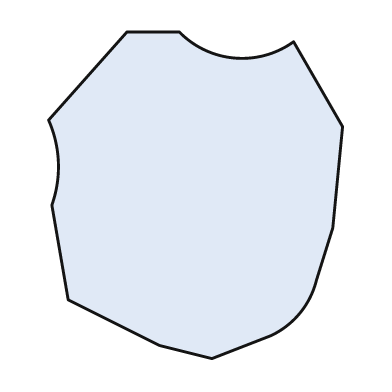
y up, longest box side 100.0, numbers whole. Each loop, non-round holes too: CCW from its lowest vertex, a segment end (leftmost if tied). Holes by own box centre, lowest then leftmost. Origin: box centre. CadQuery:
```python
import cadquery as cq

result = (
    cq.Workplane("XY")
    .moveTo(5.0, -50.0)
    .lineTo(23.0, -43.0)
    .threePointArc((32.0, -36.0), (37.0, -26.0))
    .lineTo(42.0, -10.0)
    .lineTo(45.0, 21.0)
    .lineTo(30.0, 47.0)
    .threePointArc((12.0, 42.0), (-5.0, 50.0))
    .lineTo(-21.0, 50.0)
    .lineTo(-45.0, 23.0)
    .threePointArc((-42.0, 10.0), (-44.0, -3.0))
    .lineTo(-39.0, -32.0)
    .lineTo(-11.0, -46.0)
    .close()
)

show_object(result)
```